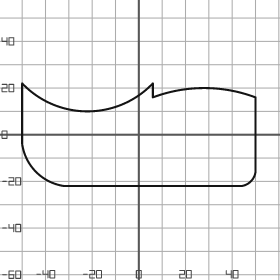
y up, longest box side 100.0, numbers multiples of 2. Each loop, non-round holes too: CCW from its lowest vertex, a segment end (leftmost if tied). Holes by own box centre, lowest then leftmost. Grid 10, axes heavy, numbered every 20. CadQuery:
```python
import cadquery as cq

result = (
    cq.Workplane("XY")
    .moveTo(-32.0, -22.0)
    .lineTo(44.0, -22.0)
    .threePointArc((48.0, -20.0), (50.0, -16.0))
    .lineTo(50.0, 16.0)
    .threePointArc((28.0, 20.0), (6.0, 16.0))
    .lineTo(6.0, 22.0)
    .threePointArc((-22.0, 10.0), (-50.0, 22.0))
    .lineTo(-50.0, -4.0)
    .threePointArc((-44.0, -16.0), (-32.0, -22.0))
    .close()
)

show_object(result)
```